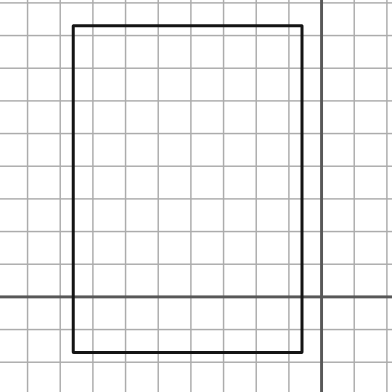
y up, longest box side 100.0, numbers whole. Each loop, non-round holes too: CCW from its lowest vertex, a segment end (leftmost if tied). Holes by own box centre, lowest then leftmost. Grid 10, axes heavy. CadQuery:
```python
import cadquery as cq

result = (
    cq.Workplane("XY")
    .moveTo(-76.0, -17.0)
    .lineTo(-6.0, -17.0)
    .lineTo(-6.0, 83.0)
    .lineTo(-76.0, 83.0)
    .close()
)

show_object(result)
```